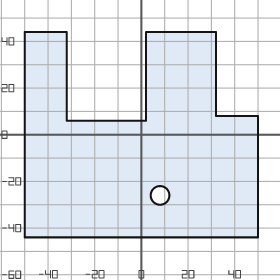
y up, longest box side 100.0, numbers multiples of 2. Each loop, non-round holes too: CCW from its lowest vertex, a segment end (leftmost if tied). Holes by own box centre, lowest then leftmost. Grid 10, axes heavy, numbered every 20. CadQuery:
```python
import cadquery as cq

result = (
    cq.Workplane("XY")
    .moveTo(-50.0, -44.0)
    .lineTo(50.0, -44.0)
    .lineTo(50.0, 8.0)
    .lineTo(32.0, 8.0)
    .lineTo(32.0, 44.0)
    .lineTo(2.0, 44.0)
    .lineTo(2.0, 6.0)
    .lineTo(-32.0, 6.0)
    .lineTo(-32.0, 44.0)
    .lineTo(-50.0, 44.0)
    .close()
    .moveTo(8.0, -26.0)
    .circle(4.0)
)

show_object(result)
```